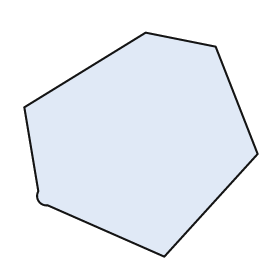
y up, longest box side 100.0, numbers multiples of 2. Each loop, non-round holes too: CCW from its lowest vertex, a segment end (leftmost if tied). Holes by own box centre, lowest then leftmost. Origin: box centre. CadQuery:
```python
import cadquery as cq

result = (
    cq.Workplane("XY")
    .moveTo(10.0, -48.0)
    .lineTo(50.0, -4.0)
    .lineTo(32.0, 42.0)
    .lineTo(2.0, 48.0)
    .lineTo(-50.0, 16.0)
    .lineTo(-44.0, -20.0)
    .threePointArc((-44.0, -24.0), (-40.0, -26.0))
    .close()
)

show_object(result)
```